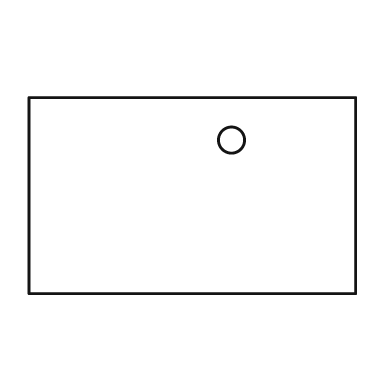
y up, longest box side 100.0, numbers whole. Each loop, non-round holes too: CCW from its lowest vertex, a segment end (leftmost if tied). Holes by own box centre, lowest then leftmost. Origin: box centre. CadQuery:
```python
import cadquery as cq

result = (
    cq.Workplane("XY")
    .moveTo(-50.0, -30.0)
    .lineTo(50.0, -30.0)
    .lineTo(50.0, 30.0)
    .lineTo(-50.0, 30.0)
    .close()
    .moveTo(12.0, 17.0)
    .circle(4.0)
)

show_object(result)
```